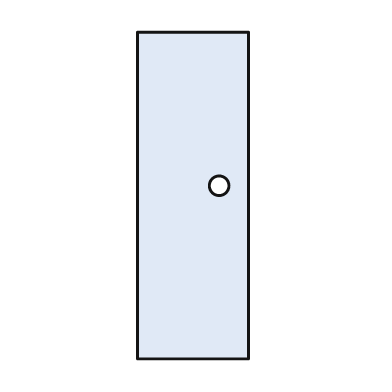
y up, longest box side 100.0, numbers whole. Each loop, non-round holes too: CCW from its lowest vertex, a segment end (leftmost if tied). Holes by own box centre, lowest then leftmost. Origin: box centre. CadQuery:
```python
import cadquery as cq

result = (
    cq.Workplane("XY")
    .moveTo(-17.0, -50.0)
    .lineTo(17.0, -50.0)
    .lineTo(17.0, 50.0)
    .lineTo(-17.0, 50.0)
    .close()
    .moveTo(8.0, 3.0)
    .circle(3.0)
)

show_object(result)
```